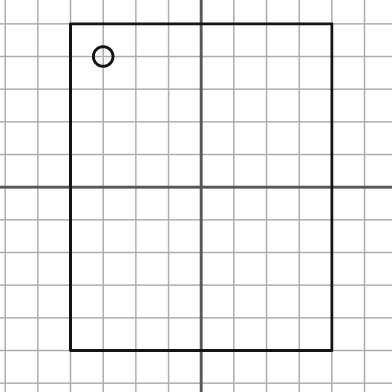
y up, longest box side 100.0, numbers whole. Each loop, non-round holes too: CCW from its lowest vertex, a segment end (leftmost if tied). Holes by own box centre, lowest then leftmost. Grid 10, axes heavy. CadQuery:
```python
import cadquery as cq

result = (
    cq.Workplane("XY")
    .moveTo(-40.0, -50.0)
    .lineTo(40.0, -50.0)
    .lineTo(40.0, 50.0)
    .lineTo(-40.0, 50.0)
    .close()
    .moveTo(-30.0, 40.0)
    .circle(3.0)
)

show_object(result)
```